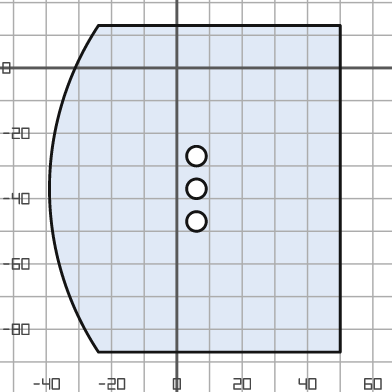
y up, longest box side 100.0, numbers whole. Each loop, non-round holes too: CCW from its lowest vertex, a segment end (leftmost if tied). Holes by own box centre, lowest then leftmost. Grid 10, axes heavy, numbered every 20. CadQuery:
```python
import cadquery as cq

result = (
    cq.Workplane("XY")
    .moveTo(-24.0, -87.0)
    .lineTo(50.0, -87.0)
    .lineTo(50.0, 13.0)
    .lineTo(-24.0, 13.0)
    .threePointArc((-39.0, -37.0), (-24.0, -87.0))
    .close()
    .moveTo(6.0, -47.0)
    .circle(3.0)
    .moveTo(6.0, -37.0)
    .circle(3.0)
    .moveTo(6.0, -27.0)
    .circle(3.0)
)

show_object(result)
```